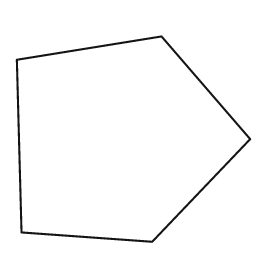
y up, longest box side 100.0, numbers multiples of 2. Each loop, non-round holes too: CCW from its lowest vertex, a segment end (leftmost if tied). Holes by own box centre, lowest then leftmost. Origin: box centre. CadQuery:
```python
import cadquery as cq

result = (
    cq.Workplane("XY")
    .moveTo(8.0, -44.0)
    .lineTo(50.0, 0.0)
    .lineTo(12.0, 44.0)
    .lineTo(-50.0, 34.0)
    .lineTo(-48.0, -40.0)
    .close()
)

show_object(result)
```